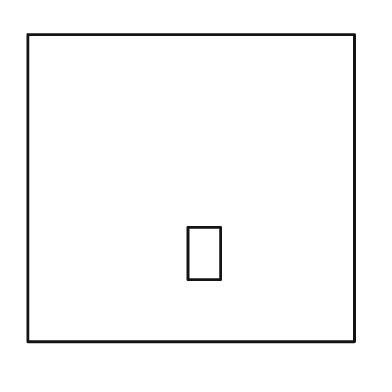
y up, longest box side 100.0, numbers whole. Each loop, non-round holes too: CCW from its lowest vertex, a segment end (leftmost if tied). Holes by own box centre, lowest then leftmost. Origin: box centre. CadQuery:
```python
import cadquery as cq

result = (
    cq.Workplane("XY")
    .moveTo(-50.0, -47.0)
    .lineTo(50.0, -47.0)
    .lineTo(50.0, 47.0)
    .lineTo(-50.0, 47.0)
    .close()
    .moveTo(-1.0, -28.0)
    .lineTo(9.0, -28.0)
    .lineTo(9.0, -12.0)
    .lineTo(-1.0, -12.0)
    .close()
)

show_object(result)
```